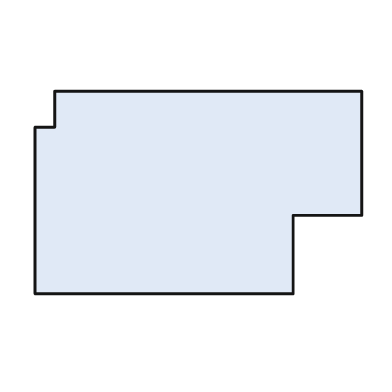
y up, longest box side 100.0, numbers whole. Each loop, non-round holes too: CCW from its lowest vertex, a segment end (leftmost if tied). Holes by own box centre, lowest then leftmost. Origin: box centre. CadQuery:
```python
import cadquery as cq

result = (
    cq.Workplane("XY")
    .moveTo(-50.0, -31.0)
    .lineTo(29.0, -31.0)
    .lineTo(29.0, -7.0)
    .lineTo(50.0, -7.0)
    .lineTo(50.0, 31.0)
    .lineTo(-44.0, 31.0)
    .lineTo(-44.0, 20.0)
    .lineTo(-50.0, 20.0)
    .close()
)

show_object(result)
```